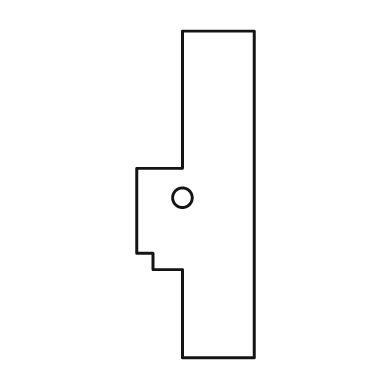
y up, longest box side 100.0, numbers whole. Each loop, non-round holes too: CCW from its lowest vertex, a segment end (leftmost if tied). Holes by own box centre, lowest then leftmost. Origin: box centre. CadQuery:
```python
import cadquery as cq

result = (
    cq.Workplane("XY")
    .moveTo(-4.0, -50.0)
    .lineTo(18.0, -50.0)
    .lineTo(18.0, 50.0)
    .lineTo(-4.0, 50.0)
    .lineTo(-4.0, 8.0)
    .lineTo(-18.0, 8.0)
    .lineTo(-18.0, -18.0)
    .lineTo(-13.0, -18.0)
    .lineTo(-13.0, -23.0)
    .lineTo(-4.0, -23.0)
    .close()
    .moveTo(-4.0, -1.0)
    .circle(3.0)
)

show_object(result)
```